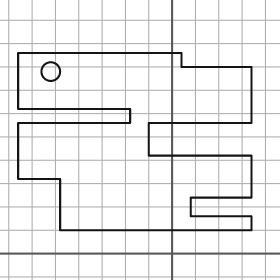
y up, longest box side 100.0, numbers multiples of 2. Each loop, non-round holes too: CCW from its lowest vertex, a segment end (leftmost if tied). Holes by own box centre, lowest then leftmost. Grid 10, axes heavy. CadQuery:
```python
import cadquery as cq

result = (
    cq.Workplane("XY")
    .moveTo(-48.0, 10.0)
    .lineTo(34.0, 10.0)
    .lineTo(34.0, 16.0)
    .lineTo(8.0, 16.0)
    .lineTo(8.0, 24.0)
    .lineTo(34.0, 24.0)
    .lineTo(34.0, 42.0)
    .lineTo(-10.0, 42.0)
    .lineTo(-10.0, 56.0)
    .lineTo(34.0, 56.0)
    .lineTo(34.0, 80.0)
    .lineTo(4.0, 80.0)
    .lineTo(4.0, 86.0)
    .lineTo(-66.0, 86.0)
    .lineTo(-66.0, 62.0)
    .lineTo(-18.0, 62.0)
    .lineTo(-18.0, 56.0)
    .lineTo(-66.0, 56.0)
    .lineTo(-66.0, 32.0)
    .lineTo(-48.0, 32.0)
    .close()
    .moveTo(-52.0, 78.0)
    .circle(4.0)
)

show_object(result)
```